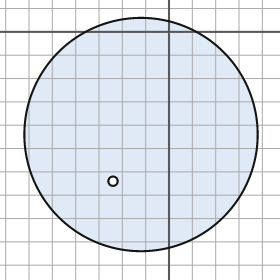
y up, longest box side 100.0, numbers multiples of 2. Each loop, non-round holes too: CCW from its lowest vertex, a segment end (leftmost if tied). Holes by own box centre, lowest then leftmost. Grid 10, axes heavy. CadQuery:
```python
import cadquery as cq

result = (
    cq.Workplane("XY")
    .moveTo(-12.0, -44.0)
    .circle(50.0)
    .moveTo(-24.0, -64.0)
    .circle(2.0)
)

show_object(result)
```